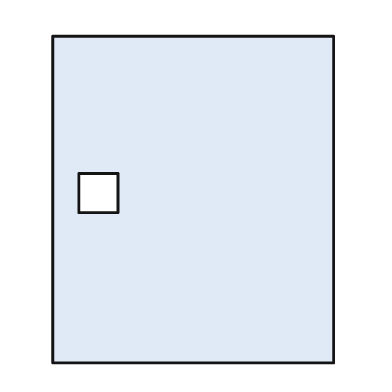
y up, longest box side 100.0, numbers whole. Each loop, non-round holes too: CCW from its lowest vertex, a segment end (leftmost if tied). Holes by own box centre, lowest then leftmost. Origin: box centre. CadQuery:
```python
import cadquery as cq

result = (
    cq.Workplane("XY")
    .moveTo(-43.0, -50.0)
    .lineTo(43.0, -50.0)
    .lineTo(43.0, 50.0)
    .lineTo(-43.0, 50.0)
    .close()
    .moveTo(-35.0, -4.0)
    .lineTo(-23.0, -4.0)
    .lineTo(-23.0, 8.0)
    .lineTo(-35.0, 8.0)
    .close()
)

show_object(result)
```